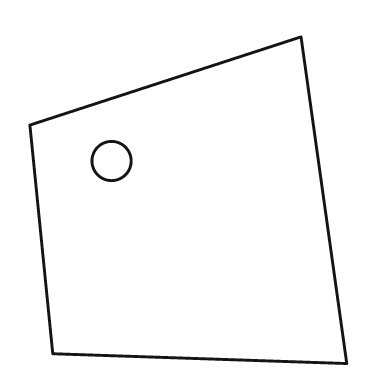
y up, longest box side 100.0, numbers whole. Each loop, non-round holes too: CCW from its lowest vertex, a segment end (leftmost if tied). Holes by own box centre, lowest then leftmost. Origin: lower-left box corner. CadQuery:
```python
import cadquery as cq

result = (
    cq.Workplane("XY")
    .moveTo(97.0, 0.0)
    .lineTo(83.0, 100.0)
    .lineTo(0.0, 73.0)
    .lineTo(7.0, 3.0)
    .close()
    .moveTo(25.0, 62.0)
    .circle(6.0)
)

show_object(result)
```